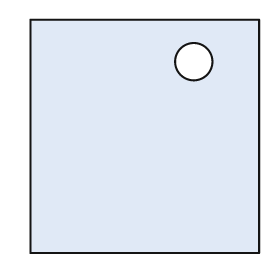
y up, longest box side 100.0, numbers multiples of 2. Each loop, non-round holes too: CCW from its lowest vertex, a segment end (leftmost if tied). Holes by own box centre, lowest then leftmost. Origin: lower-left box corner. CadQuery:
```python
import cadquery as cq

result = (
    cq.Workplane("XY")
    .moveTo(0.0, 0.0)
    .lineTo(98.0, 0.0)
    .lineTo(98.0, 100.0)
    .lineTo(0.0, 100.0)
    .close()
    .moveTo(70.0, 82.0)
    .circle(8.0)
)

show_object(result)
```